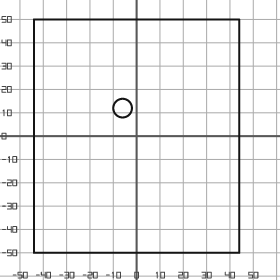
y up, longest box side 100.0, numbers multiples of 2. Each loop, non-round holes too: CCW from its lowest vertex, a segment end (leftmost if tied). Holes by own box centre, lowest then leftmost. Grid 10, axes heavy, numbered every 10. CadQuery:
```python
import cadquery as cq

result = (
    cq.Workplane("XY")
    .moveTo(-44.0, -50.0)
    .lineTo(44.0, -50.0)
    .lineTo(44.0, 50.0)
    .lineTo(-44.0, 50.0)
    .close()
    .moveTo(-6.0, 12.0)
    .circle(4.0)
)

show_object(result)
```